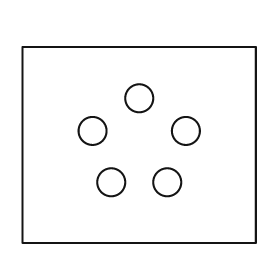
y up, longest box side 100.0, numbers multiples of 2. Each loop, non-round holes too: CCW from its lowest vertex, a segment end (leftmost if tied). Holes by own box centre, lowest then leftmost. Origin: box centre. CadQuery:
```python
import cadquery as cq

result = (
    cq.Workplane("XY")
    .moveTo(-50.0, -42.0)
    .lineTo(50.0, -42.0)
    .lineTo(50.0, 42.0)
    .lineTo(-50.0, 42.0)
    .close()
    .moveTo(-12.0, -16.0)
    .circle(6.0)
    .moveTo(12.0, -16.0)
    .circle(6.0)
    .moveTo(-20.0, 6.0)
    .circle(6.0)
    .moveTo(20.0, 6.0)
    .circle(6.0)
    .moveTo(0.0, 20.0)
    .circle(6.0)
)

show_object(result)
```